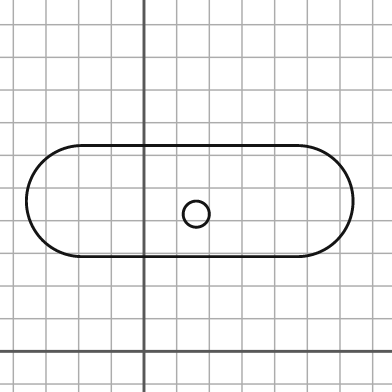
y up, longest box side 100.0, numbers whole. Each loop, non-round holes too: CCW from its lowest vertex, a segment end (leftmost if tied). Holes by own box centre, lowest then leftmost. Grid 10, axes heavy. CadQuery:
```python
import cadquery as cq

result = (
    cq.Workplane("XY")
    .moveTo(-19.0, 29.0)
    .lineTo(47.0, 29.0)
    .threePointArc((64.0, 46.0), (47.0, 63.0))
    .lineTo(-19.0, 63.0)
    .threePointArc((-36.0, 46.0), (-19.0, 29.0))
    .close()
    .moveTo(16.0, 42.0)
    .circle(4.0)
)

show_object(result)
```